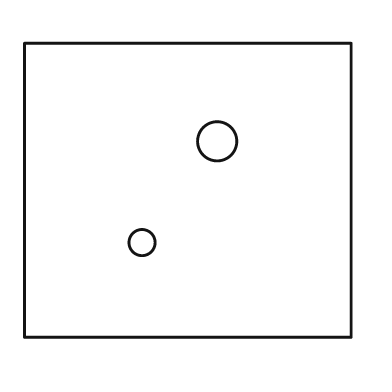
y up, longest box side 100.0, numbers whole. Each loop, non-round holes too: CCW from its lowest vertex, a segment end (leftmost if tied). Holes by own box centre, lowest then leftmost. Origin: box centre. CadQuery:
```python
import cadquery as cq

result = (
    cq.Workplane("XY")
    .moveTo(-50.0, -45.0)
    .lineTo(50.0, -45.0)
    .lineTo(50.0, 45.0)
    .lineTo(-50.0, 45.0)
    .close()
    .moveTo(-14.0, -16.0)
    .circle(4.0)
    .moveTo(9.0, 15.0)
    .circle(6.0)
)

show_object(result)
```